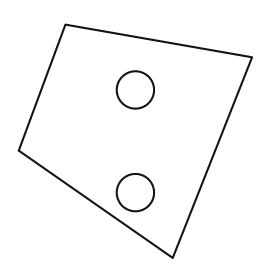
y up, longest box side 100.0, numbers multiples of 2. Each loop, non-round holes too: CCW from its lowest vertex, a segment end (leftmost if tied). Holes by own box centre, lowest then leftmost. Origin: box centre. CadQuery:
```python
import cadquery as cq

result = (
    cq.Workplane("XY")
    .moveTo(16.0, -50.0)
    .lineTo(50.0, 36.0)
    .lineTo(-30.0, 50.0)
    .lineTo(-50.0, -4.0)
    .close()
    .moveTo(0.0, -22.0)
    .circle(8.0)
    .moveTo(0.0, 22.0)
    .circle(8.0)
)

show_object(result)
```